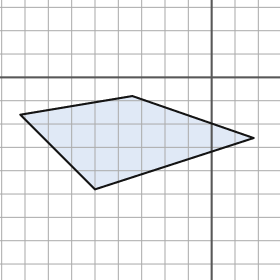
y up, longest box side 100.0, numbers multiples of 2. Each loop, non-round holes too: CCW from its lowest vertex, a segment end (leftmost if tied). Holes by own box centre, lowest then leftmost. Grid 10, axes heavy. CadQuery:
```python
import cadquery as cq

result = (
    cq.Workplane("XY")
    .moveTo(-50.0, -48.0)
    .lineTo(18.0, -26.0)
    .lineTo(-34.0, -8.0)
    .lineTo(-82.0, -16.0)
    .close()
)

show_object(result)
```